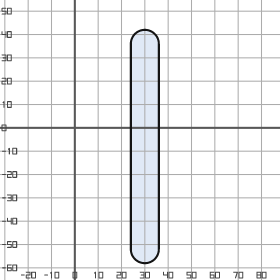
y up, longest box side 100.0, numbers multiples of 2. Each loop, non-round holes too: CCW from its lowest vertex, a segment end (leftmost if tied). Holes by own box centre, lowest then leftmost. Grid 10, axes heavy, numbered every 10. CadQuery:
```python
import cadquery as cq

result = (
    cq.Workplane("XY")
    .moveTo(24.0, -52.0)
    .threePointArc((30.0, -58.0), (36.0, -52.0))
    .lineTo(36.0, 36.0)
    .threePointArc((30.0, 42.0), (24.0, 36.0))
    .close()
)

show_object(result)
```